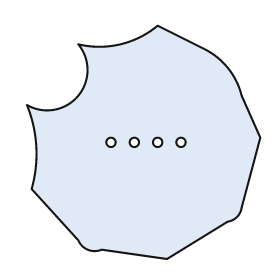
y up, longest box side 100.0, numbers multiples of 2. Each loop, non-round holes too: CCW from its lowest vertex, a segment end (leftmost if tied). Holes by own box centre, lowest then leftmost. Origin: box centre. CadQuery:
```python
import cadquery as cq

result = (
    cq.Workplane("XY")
    .moveTo(10.0, -50.0)
    .lineTo(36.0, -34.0)
    .threePointArc((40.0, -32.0), (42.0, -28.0))
    .lineTo(50.0, 2.0)
    .lineTo(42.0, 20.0)
    .threePointArc((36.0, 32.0), (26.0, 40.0))
    .lineTo(6.0, 50.0)
    .threePointArc((-10.0, 42.0), (-28.0, 42.0))
    .threePointArc((-28.0, 20.0), (-50.0, 16.0))
    .threePointArc((-46.0, -2.0), (-48.0, -20.0))
    .lineTo(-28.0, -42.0)
    .threePointArc((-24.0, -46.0), (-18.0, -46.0))
    .close()
    .moveTo(-14.0, 0.0)
    .circle(2.0)
    .moveTo(-4.0, 0.0)
    .circle(2.0)
    .moveTo(6.0, 0.0)
    .circle(2.0)
    .moveTo(16.0, 0.0)
    .circle(2.0)
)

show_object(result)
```